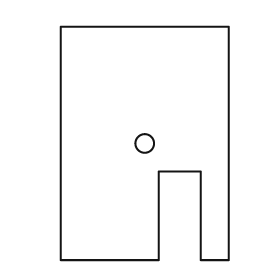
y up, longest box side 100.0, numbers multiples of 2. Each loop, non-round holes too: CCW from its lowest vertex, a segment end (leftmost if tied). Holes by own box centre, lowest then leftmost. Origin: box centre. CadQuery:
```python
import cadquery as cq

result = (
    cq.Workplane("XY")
    .moveTo(-36.0, -50.0)
    .lineTo(6.0, -50.0)
    .lineTo(6.0, -12.0)
    .lineTo(24.0, -12.0)
    .lineTo(24.0, -50.0)
    .lineTo(36.0, -50.0)
    .lineTo(36.0, 50.0)
    .lineTo(-36.0, 50.0)
    .close()
    .moveTo(0.0, 0.0)
    .circle(4.0)
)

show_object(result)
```